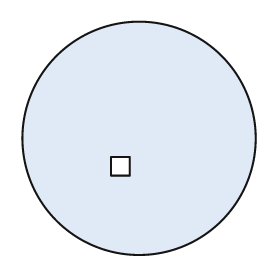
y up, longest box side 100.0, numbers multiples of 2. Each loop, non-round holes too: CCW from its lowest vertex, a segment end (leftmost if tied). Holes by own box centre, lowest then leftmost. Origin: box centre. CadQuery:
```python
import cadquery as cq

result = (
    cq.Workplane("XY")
    .moveTo(0.0, 0.0)
    .circle(50.0)
    .moveTo(-12.0, -16.0)
    .lineTo(-4.0, -16.0)
    .lineTo(-4.0, -8.0)
    .lineTo(-12.0, -8.0)
    .close()
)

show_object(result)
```